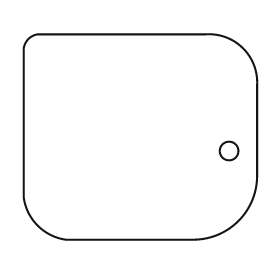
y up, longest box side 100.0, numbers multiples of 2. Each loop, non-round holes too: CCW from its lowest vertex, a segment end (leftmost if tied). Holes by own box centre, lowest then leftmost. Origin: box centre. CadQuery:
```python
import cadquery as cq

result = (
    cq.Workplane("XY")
    .moveTo(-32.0, -44.0)
    .lineTo(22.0, -44.0)
    .threePointArc((42.0, -36.0), (50.0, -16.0))
    .lineTo(50.0, 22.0)
    .threePointArc((44.0, 38.0), (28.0, 44.0))
    .lineTo(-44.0, 44.0)
    .threePointArc((-48.0, 42.0), (-50.0, 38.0))
    .lineTo(-50.0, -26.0)
    .threePointArc((-44.0, -38.0), (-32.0, -44.0))
    .close()
    .moveTo(38.0, -6.0)
    .circle(4.0)
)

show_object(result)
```